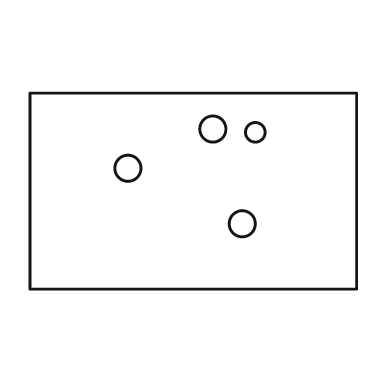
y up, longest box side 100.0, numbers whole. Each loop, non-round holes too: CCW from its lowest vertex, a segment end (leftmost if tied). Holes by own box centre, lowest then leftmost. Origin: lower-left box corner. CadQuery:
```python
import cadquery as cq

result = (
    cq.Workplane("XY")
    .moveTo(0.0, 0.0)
    .lineTo(100.0, 0.0)
    .lineTo(100.0, 60.0)
    .lineTo(0.0, 60.0)
    .close()
    .moveTo(65.0, 20.0)
    .circle(4.0)
    .moveTo(30.0, 37.0)
    .circle(4.0)
    .moveTo(69.0, 48.0)
    .circle(3.0)
    .moveTo(56.0, 49.0)
    .circle(4.0)
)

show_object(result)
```